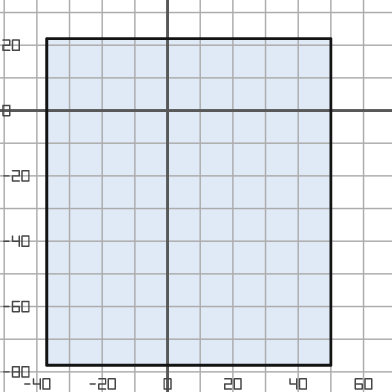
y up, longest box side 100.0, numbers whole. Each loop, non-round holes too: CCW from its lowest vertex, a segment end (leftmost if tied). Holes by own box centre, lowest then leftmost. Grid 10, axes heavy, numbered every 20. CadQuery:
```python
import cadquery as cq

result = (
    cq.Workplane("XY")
    .moveTo(-37.0, -78.0)
    .lineTo(50.0, -78.0)
    .lineTo(50.0, 22.0)
    .lineTo(-37.0, 22.0)
    .close()
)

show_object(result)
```